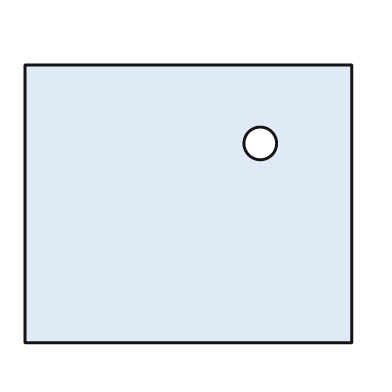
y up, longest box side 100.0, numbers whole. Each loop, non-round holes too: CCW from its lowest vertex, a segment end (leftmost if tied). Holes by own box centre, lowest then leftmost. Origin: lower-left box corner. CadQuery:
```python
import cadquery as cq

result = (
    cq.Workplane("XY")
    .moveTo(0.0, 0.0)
    .lineTo(100.0, 0.0)
    .lineTo(100.0, 85.0)
    .lineTo(0.0, 85.0)
    .close()
    .moveTo(72.0, 61.0)
    .circle(5.0)
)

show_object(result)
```